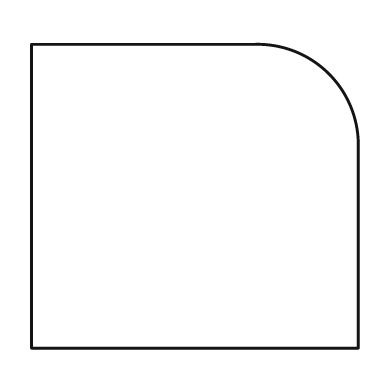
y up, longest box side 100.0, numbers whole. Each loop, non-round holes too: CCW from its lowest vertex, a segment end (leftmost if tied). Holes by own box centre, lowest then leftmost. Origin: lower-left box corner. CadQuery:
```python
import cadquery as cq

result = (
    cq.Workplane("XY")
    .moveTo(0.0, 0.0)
    .lineTo(100.0, 0.0)
    .lineTo(100.0, 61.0)
    .threePointArc((91.0, 84.0), (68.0, 93.0))
    .lineTo(0.0, 93.0)
    .close()
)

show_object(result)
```